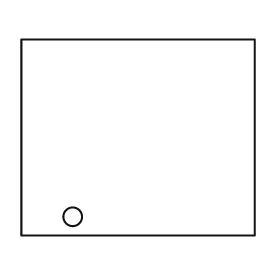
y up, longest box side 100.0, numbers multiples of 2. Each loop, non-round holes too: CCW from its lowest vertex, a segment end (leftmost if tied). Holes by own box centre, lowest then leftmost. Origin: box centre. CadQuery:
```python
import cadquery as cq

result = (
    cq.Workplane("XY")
    .moveTo(-50.0, -42.0)
    .lineTo(50.0, -42.0)
    .lineTo(50.0, 42.0)
    .lineTo(-50.0, 42.0)
    .close()
    .moveTo(-28.0, -34.0)
    .circle(4.0)
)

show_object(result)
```